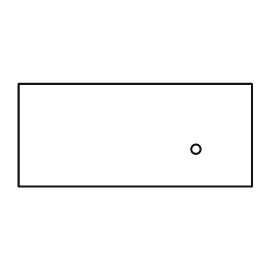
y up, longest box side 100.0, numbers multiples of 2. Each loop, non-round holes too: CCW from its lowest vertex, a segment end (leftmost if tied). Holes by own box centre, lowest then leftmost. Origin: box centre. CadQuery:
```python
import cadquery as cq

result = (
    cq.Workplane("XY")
    .moveTo(-50.0, -22.0)
    .lineTo(50.0, -22.0)
    .lineTo(50.0, 22.0)
    .lineTo(-50.0, 22.0)
    .close()
    .moveTo(26.0, -6.0)
    .circle(2.0)
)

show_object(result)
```